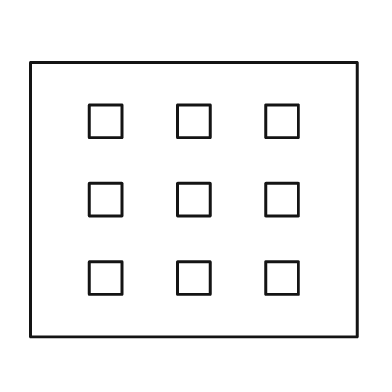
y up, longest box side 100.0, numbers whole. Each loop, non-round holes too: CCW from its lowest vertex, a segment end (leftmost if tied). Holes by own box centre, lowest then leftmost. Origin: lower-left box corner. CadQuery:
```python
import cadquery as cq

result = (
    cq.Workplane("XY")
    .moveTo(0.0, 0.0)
    .lineTo(100.0, 0.0)
    .lineTo(100.0, 84.0)
    .lineTo(0.0, 84.0)
    .close()
    .moveTo(18.0, 13.0)
    .lineTo(28.0, 13.0)
    .lineTo(28.0, 23.0)
    .lineTo(18.0, 23.0)
    .close()
    .moveTo(45.0, 13.0)
    .lineTo(55.0, 13.0)
    .lineTo(55.0, 23.0)
    .lineTo(45.0, 23.0)
    .close()
    .moveTo(72.0, 13.0)
    .lineTo(82.0, 13.0)
    .lineTo(82.0, 23.0)
    .lineTo(72.0, 23.0)
    .close()
    .moveTo(18.0, 37.0)
    .lineTo(28.0, 37.0)
    .lineTo(28.0, 47.0)
    .lineTo(18.0, 47.0)
    .close()
    .moveTo(45.0, 37.0)
    .lineTo(55.0, 37.0)
    .lineTo(55.0, 47.0)
    .lineTo(45.0, 47.0)
    .close()
    .moveTo(72.0, 37.0)
    .lineTo(82.0, 37.0)
    .lineTo(82.0, 47.0)
    .lineTo(72.0, 47.0)
    .close()
    .moveTo(18.0, 61.0)
    .lineTo(28.0, 61.0)
    .lineTo(28.0, 71.0)
    .lineTo(18.0, 71.0)
    .close()
    .moveTo(45.0, 61.0)
    .lineTo(55.0, 61.0)
    .lineTo(55.0, 71.0)
    .lineTo(45.0, 71.0)
    .close()
    .moveTo(72.0, 61.0)
    .lineTo(82.0, 61.0)
    .lineTo(82.0, 71.0)
    .lineTo(72.0, 71.0)
    .close()
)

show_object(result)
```